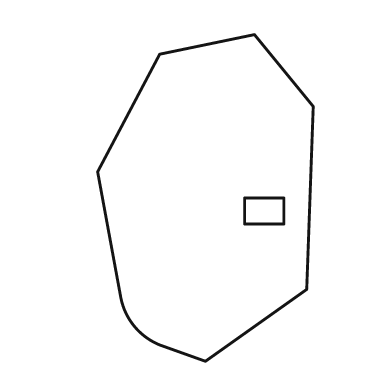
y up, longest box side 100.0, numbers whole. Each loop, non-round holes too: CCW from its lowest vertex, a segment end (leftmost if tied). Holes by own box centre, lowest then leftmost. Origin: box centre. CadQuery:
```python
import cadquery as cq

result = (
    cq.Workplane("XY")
    .moveTo(0.0, -50.0)
    .lineTo(31.0, -28.0)
    .lineTo(33.0, 28.0)
    .lineTo(15.0, 50.0)
    .lineTo(-14.0, 44.0)
    .lineTo(-33.0, 8.0)
    .lineTo(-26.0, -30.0)
    .threePointArc((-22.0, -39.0), (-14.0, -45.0))
    .close()
    .moveTo(12.0, -8.0)
    .lineTo(24.0, -8.0)
    .lineTo(24.0, 0.0)
    .lineTo(12.0, 0.0)
    .close()
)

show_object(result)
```